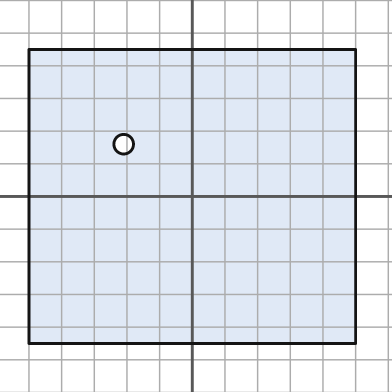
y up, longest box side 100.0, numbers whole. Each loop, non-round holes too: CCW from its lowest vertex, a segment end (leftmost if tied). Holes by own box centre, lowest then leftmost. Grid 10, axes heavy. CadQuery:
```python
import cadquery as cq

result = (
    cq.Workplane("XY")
    .moveTo(-50.0, -45.0)
    .lineTo(50.0, -45.0)
    .lineTo(50.0, 45.0)
    .lineTo(-50.0, 45.0)
    .close()
    .moveTo(-21.0, 16.0)
    .circle(3.0)
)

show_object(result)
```